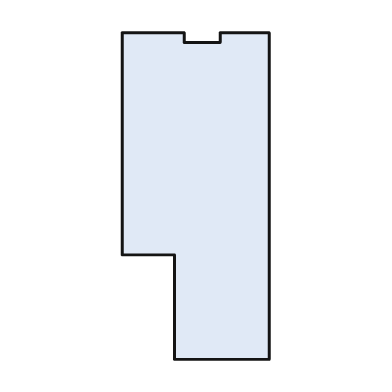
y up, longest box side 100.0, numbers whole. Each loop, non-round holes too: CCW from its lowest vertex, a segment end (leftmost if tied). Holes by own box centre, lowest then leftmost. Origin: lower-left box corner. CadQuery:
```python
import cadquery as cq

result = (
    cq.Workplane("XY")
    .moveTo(16.0, 0.0)
    .lineTo(45.0, 0.0)
    .lineTo(45.0, 100.0)
    .lineTo(30.0, 100.0)
    .lineTo(30.0, 97.0)
    .lineTo(19.0, 97.0)
    .lineTo(19.0, 100.0)
    .lineTo(0.0, 100.0)
    .lineTo(0.0, 32.0)
    .lineTo(16.0, 32.0)
    .close()
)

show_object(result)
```